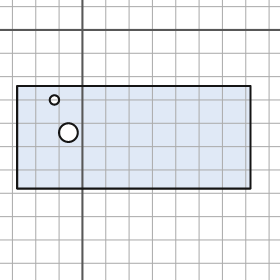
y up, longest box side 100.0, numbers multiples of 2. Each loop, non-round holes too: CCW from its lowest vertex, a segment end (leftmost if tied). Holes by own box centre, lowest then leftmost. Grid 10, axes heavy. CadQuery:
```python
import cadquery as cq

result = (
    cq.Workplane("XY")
    .moveTo(-28.0, -68.0)
    .lineTo(72.0, -68.0)
    .lineTo(72.0, -24.0)
    .lineTo(-28.0, -24.0)
    .close()
    .moveTo(-6.0, -44.0)
    .circle(4.0)
    .moveTo(-12.0, -30.0)
    .circle(2.0)
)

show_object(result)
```